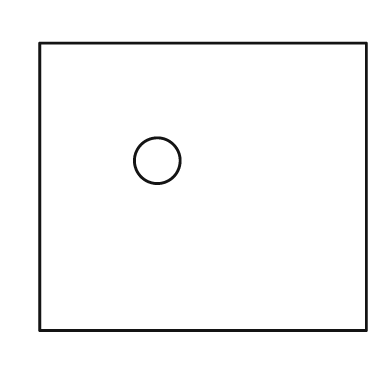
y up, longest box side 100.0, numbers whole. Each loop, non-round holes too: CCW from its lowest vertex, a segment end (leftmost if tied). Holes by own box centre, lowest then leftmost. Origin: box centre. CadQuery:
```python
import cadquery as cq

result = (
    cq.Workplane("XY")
    .moveTo(-50.0, -44.0)
    .lineTo(50.0, -44.0)
    .lineTo(50.0, 44.0)
    .lineTo(-50.0, 44.0)
    .close()
    .moveTo(-14.0, 8.0)
    .circle(7.0)
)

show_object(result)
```